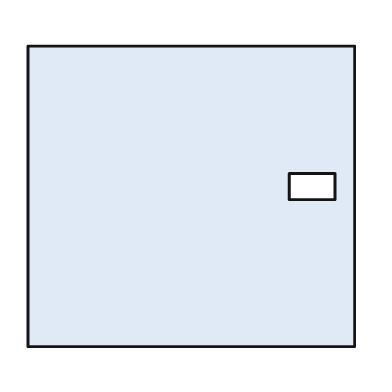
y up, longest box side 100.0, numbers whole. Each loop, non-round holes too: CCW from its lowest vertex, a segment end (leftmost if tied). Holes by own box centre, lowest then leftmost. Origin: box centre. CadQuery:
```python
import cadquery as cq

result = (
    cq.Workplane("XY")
    .moveTo(-50.0, -46.0)
    .lineTo(50.0, -46.0)
    .lineTo(50.0, 46.0)
    .lineTo(-50.0, 46.0)
    .close()
    .moveTo(30.0, -1.0)
    .lineTo(44.0, -1.0)
    .lineTo(44.0, 7.0)
    .lineTo(30.0, 7.0)
    .close()
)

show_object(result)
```